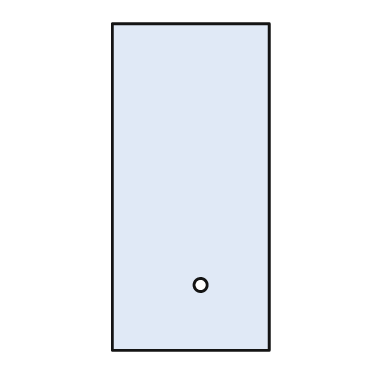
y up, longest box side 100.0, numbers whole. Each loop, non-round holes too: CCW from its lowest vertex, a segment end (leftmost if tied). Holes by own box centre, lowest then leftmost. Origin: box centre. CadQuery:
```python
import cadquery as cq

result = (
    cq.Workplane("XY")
    .moveTo(-24.0, -50.0)
    .lineTo(24.0, -50.0)
    .lineTo(24.0, 50.0)
    .lineTo(-24.0, 50.0)
    .close()
    .moveTo(3.0, -30.0)
    .circle(2.0)
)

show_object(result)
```